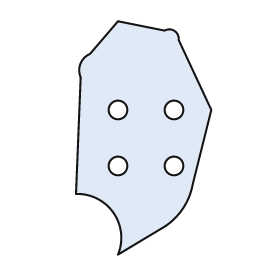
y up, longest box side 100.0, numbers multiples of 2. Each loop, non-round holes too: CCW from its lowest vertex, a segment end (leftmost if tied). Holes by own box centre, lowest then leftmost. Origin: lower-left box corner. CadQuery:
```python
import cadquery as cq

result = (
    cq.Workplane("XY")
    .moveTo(18.0, 0.0)
    .lineTo(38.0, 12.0)
    .threePointArc((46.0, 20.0), (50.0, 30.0))
    .lineTo(58.0, 62.0)
    .lineTo(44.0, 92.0)
    .threePointArc((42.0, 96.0), (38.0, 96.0))
    .lineTo(18.0, 100.0)
    .lineTo(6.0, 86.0)
    .threePointArc((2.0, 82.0), (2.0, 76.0))
    .lineTo(0.0, 26.0)
    .threePointArc((16.0, 18.0), (18.0, 0.0))
    .close()
    .moveTo(18.0, 38.0)
    .circle(4.0)
    .moveTo(42.0, 38.0)
    .circle(4.0)
    .moveTo(18.0, 62.0)
    .circle(4.0)
    .moveTo(42.0, 62.0)
    .circle(4.0)
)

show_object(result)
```